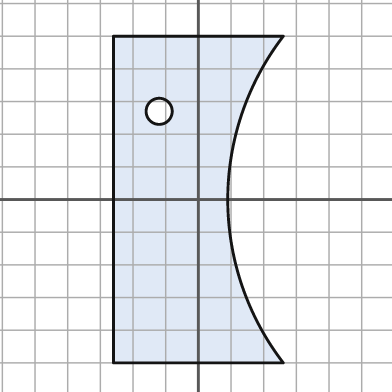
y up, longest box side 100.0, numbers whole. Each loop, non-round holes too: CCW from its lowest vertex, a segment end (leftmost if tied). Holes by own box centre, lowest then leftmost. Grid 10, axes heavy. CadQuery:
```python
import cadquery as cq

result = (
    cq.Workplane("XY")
    .moveTo(-26.0, -50.0)
    .lineTo(26.0, -50.0)
    .threePointArc((9.0, 0.0), (26.0, 50.0))
    .lineTo(-26.0, 50.0)
    .close()
    .moveTo(-12.0, 27.0)
    .circle(4.0)
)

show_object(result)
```